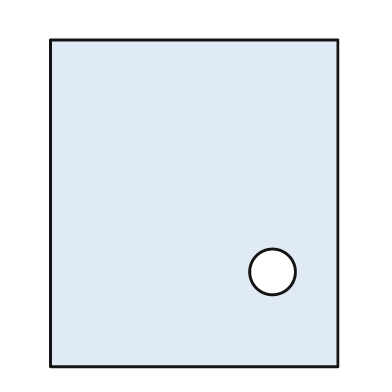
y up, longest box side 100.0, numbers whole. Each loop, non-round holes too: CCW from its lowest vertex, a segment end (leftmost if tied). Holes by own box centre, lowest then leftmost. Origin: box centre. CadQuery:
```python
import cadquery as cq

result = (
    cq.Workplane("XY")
    .moveTo(-44.0, -50.0)
    .lineTo(44.0, -50.0)
    .lineTo(44.0, 50.0)
    .lineTo(-44.0, 50.0)
    .close()
    .moveTo(24.0, -21.0)
    .circle(7.0)
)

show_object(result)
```